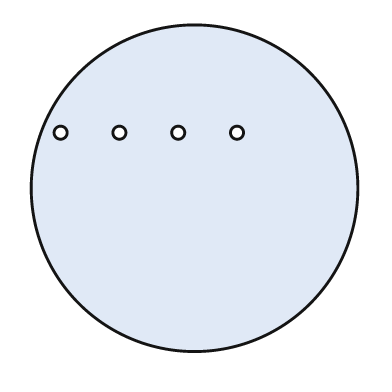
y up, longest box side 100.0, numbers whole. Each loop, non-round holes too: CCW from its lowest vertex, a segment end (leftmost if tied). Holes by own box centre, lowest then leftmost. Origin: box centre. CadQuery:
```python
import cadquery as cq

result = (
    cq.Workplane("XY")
    .moveTo(0.0, 0.0)
    .circle(50.0)
    .moveTo(-41.0, 17.0)
    .circle(2.0)
    .moveTo(-23.0, 17.0)
    .circle(2.0)
    .moveTo(-5.0, 17.0)
    .circle(2.0)
    .moveTo(13.0, 17.0)
    .circle(2.0)
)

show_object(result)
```